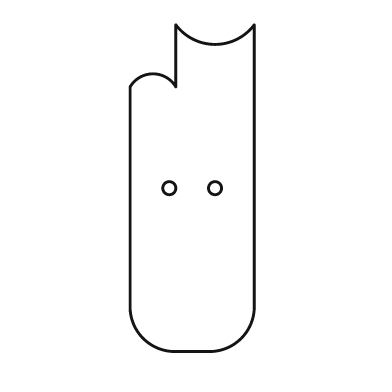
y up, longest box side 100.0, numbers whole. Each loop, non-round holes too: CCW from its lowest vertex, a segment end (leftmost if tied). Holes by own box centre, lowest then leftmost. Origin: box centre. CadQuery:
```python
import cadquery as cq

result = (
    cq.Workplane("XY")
    .moveTo(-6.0, -50.0)
    .lineTo(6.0, -50.0)
    .threePointArc((15.0, -46.0), (19.0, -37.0))
    .lineTo(19.0, 50.0)
    .threePointArc((7.0, 44.0), (-5.0, 50.0))
    .lineTo(-5.0, 31.0)
    .threePointArc((-12.0, 35.0), (-19.0, 31.0))
    .lineTo(-19.0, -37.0)
    .threePointArc((-15.0, -46.0), (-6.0, -50.0))
    .close()
    .moveTo(-7.0, 0.0)
    .circle(2.0)
    .moveTo(7.0, 0.0)
    .circle(2.0)
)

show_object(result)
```